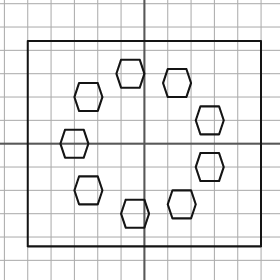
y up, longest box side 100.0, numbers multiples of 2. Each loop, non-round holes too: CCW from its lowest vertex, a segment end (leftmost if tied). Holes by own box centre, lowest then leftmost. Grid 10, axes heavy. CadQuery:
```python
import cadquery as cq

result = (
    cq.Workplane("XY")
    .moveTo(-50.0, -44.0)
    .lineTo(50.0, -44.0)
    .lineTo(50.0, 44.0)
    .lineTo(-50.0, 44.0)
    .close()
    .moveTo(-8.0, -36.0)
    .lineTo(0.0, -36.0)
    .lineTo(2.0, -30.0)
    .lineTo(0.0, -24.0)
    .lineTo(-8.0, -24.0)
    .lineTo(-10.0, -30.0)
    .close()
    .moveTo(12.0, -32.0)
    .lineTo(20.0, -32.0)
    .lineTo(22.0, -26.0)
    .lineTo(20.0, -20.0)
    .lineTo(12.0, -20.0)
    .lineTo(10.0, -26.0)
    .close()
    .moveTo(-28.0, -26.0)
    .lineTo(-20.0, -26.0)
    .lineTo(-18.0, -20.0)
    .lineTo(-20.0, -14.0)
    .lineTo(-28.0, -14.0)
    .lineTo(-30.0, -20.0)
    .close()
    .moveTo(24.0, -16.0)
    .lineTo(32.0, -16.0)
    .lineTo(34.0, -10.0)
    .lineTo(32.0, -4.0)
    .lineTo(24.0, -4.0)
    .lineTo(22.0, -10.0)
    .close()
    .moveTo(-34.0, -6.0)
    .lineTo(-26.0, -6.0)
    .lineTo(-24.0, 0.0)
    .lineTo(-26.0, 6.0)
    .lineTo(-34.0, 6.0)
    .lineTo(-36.0, 0.0)
    .close()
    .moveTo(24.0, 4.0)
    .lineTo(32.0, 4.0)
    .lineTo(34.0, 10.0)
    .lineTo(32.0, 16.0)
    .lineTo(24.0, 16.0)
    .lineTo(22.0, 10.0)
    .close()
    .moveTo(-28.0, 14.0)
    .lineTo(-20.0, 14.0)
    .lineTo(-18.0, 20.0)
    .lineTo(-20.0, 26.0)
    .lineTo(-28.0, 26.0)
    .lineTo(-30.0, 20.0)
    .close()
    .moveTo(10.0, 20.0)
    .lineTo(18.0, 20.0)
    .lineTo(20.0, 26.0)
    .lineTo(18.0, 32.0)
    .lineTo(10.0, 32.0)
    .lineTo(8.0, 26.0)
    .close()
    .moveTo(-10.0, 24.0)
    .lineTo(-2.0, 24.0)
    .lineTo(0.0, 30.0)
    .lineTo(-2.0, 36.0)
    .lineTo(-10.0, 36.0)
    .lineTo(-12.0, 30.0)
    .close()
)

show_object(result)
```